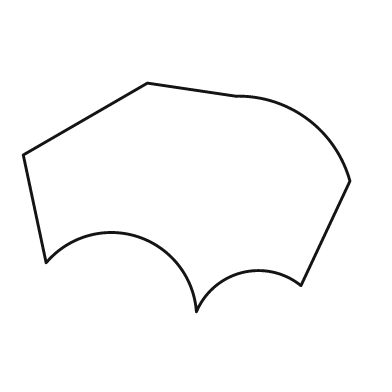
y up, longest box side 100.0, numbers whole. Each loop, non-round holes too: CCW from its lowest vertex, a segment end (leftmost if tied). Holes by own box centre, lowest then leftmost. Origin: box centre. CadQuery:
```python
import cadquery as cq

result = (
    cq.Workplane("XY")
    .moveTo(3.0, -35.0)
    .threePointArc((17.0, -23.0), (35.0, -27.0))
    .lineTo(50.0, 5.0)
    .threePointArc((37.0, 24.0), (15.0, 31.0))
    .lineTo(-12.0, 35.0)
    .lineTo(-50.0, 13.0)
    .lineTo(-43.0, -20.0)
    .threePointArc((-15.0, -12.0), (3.0, -35.0))
    .close()
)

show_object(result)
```